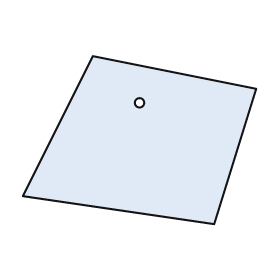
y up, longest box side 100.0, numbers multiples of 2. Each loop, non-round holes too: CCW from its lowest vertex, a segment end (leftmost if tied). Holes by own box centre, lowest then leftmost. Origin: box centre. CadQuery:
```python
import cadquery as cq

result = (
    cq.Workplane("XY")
    .moveTo(32.0, -36.0)
    .lineTo(50.0, 22.0)
    .lineTo(-20.0, 36.0)
    .lineTo(-50.0, -24.0)
    .close()
    .moveTo(0.0, 16.0)
    .circle(2.0)
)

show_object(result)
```